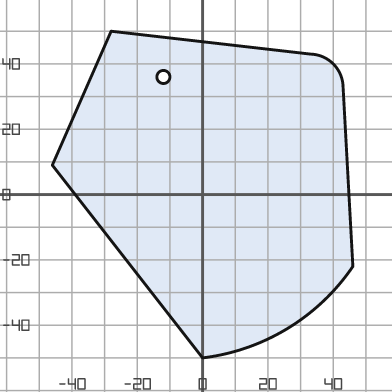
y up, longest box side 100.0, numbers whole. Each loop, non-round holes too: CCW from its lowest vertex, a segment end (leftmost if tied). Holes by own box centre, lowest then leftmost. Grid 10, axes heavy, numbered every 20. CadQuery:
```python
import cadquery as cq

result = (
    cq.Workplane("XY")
    .moveTo(0.0, -50.0)
    .threePointArc((26.0, -41.0), (46.0, -22.0))
    .lineTo(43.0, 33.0)
    .threePointArc((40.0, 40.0), (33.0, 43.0))
    .lineTo(-28.0, 50.0)
    .lineTo(-46.0, 9.0)
    .close()
    .moveTo(-12.0, 36.0)
    .circle(2.0)
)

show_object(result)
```